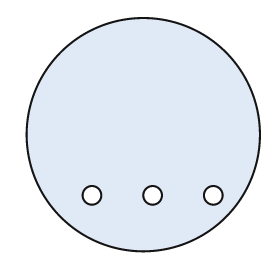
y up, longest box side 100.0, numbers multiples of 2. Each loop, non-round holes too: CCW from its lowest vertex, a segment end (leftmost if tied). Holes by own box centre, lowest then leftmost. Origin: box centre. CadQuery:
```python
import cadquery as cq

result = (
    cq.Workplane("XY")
    .moveTo(0.0, 0.0)
    .circle(50.0)
    .moveTo(-22.0, -26.0)
    .circle(4.0)
    .moveTo(4.0, -26.0)
    .circle(4.0)
    .moveTo(30.0, -26.0)
    .circle(4.0)
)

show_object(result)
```